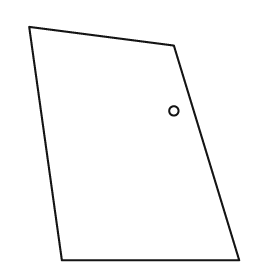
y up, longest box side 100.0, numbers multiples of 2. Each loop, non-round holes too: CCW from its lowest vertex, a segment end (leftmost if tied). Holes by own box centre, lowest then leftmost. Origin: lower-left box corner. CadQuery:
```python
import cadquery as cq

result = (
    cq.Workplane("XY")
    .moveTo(14.0, 0.0)
    .lineTo(90.0, 0.0)
    .lineTo(62.0, 92.0)
    .lineTo(0.0, 100.0)
    .close()
    .moveTo(62.0, 64.0)
    .circle(2.0)
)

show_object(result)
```